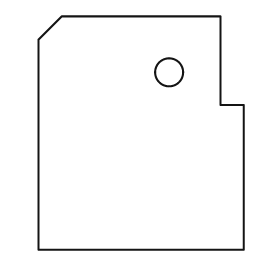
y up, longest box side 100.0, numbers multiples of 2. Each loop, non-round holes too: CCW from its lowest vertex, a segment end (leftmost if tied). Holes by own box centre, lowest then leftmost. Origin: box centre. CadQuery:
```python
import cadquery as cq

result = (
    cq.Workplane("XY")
    .moveTo(-44.0, -50.0)
    .lineTo(44.0, -50.0)
    .lineTo(44.0, 12.0)
    .lineTo(34.0, 12.0)
    .lineTo(34.0, 50.0)
    .lineTo(-34.0, 50.0)
    .lineTo(-44.0, 40.0)
    .close()
    .moveTo(12.0, 26.0)
    .circle(6.0)
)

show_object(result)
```